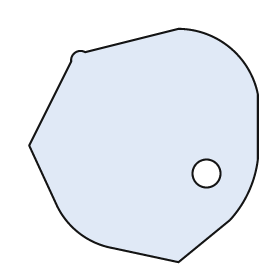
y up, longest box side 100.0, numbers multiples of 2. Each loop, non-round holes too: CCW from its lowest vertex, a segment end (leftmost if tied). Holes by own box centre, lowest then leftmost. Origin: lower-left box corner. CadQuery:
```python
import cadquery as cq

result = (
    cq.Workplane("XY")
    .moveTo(64.0, 0.0)
    .lineTo(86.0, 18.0)
    .threePointArc((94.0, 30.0), (98.0, 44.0))
    .lineTo(98.0, 72.0)
    .threePointArc((86.0, 92.0), (64.0, 100.0))
    .lineTo(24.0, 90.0)
    .threePointArc((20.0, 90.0), (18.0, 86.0))
    .lineTo(0.0, 50.0)
    .lineTo(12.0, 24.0)
    .threePointArc((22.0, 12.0), (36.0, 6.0))
    .close()
    .moveTo(76.0, 38.0)
    .circle(6.0)
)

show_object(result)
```